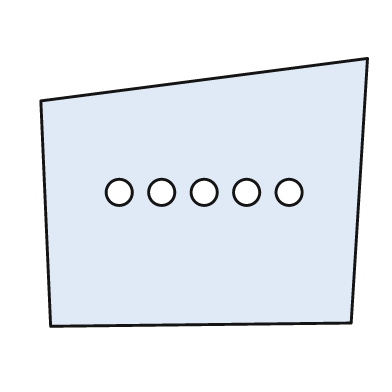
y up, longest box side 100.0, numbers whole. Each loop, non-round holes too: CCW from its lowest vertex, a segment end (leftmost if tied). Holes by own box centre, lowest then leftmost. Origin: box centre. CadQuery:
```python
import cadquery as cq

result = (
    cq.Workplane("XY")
    .moveTo(-47.0, -41.0)
    .lineTo(45.0, -40.0)
    .lineTo(50.0, 41.0)
    .lineTo(-50.0, 28.0)
    .close()
    .moveTo(-26.0, 0.0)
    .circle(4.0)
    .moveTo(-13.0, 0.0)
    .circle(4.0)
    .moveTo(0.0, 0.0)
    .circle(4.0)
    .moveTo(13.0, 0.0)
    .circle(4.0)
    .moveTo(26.0, 0.0)
    .circle(4.0)
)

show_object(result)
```